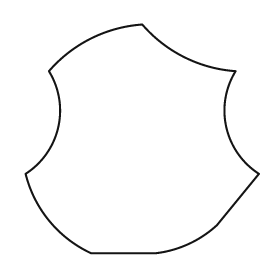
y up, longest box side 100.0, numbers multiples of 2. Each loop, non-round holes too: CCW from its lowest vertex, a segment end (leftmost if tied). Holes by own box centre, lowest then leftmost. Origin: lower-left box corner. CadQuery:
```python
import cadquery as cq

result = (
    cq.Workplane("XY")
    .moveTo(28.0, 0.0)
    .lineTo(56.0, 0.0)
    .threePointArc((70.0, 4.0), (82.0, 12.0))
    .lineTo(100.0, 34.0)
    .threePointArc((86.0, 54.0), (90.0, 78.0))
    .threePointArc((68.0, 84.0), (50.0, 98.0))
    .threePointArc((28.0, 92.0), (10.0, 78.0))
    .threePointArc((14.0, 54.0), (0.0, 34.0))
    .threePointArc((10.0, 14.0), (28.0, 0.0))
    .close()
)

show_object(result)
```